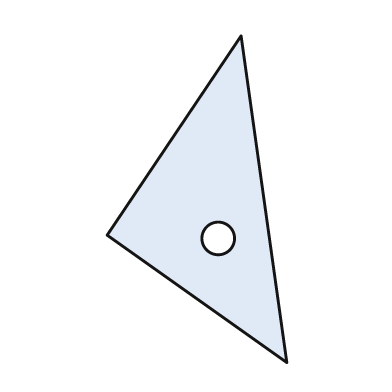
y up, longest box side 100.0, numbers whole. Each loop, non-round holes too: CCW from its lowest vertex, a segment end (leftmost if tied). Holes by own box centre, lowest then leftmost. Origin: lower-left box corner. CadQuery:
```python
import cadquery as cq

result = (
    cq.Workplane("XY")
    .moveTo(55.0, 0.0)
    .lineTo(41.0, 100.0)
    .lineTo(0.0, 39.0)
    .close()
    .moveTo(34.0, 38.0)
    .circle(5.0)
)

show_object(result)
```